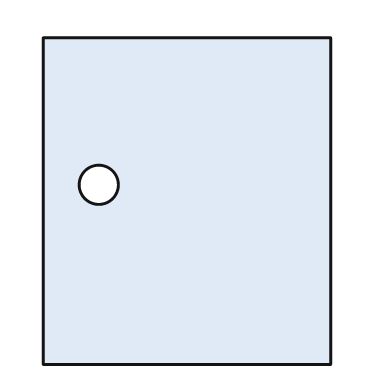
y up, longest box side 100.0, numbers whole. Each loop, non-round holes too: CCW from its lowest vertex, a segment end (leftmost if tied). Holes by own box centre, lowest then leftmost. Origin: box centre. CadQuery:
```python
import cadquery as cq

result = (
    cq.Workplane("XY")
    .moveTo(-44.0, -50.0)
    .lineTo(44.0, -50.0)
    .lineTo(44.0, 50.0)
    .lineTo(-44.0, 50.0)
    .close()
    .moveTo(-27.0, 5.0)
    .circle(6.0)
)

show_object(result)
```